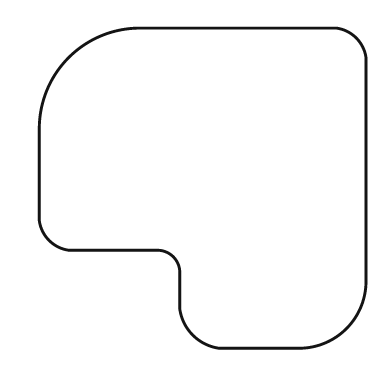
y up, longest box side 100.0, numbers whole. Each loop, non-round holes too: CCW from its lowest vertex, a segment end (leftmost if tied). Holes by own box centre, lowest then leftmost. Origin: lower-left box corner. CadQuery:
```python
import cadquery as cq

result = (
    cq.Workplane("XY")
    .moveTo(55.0, 0.0)
    .lineTo(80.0, 0.0)
    .threePointArc((94.0, 6.0), (100.0, 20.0))
    .lineTo(100.0, 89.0)
    .threePointArc((97.0, 95.0), (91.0, 98.0))
    .lineTo(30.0, 98.0)
    .threePointArc((9.0, 89.0), (0.0, 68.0))
    .lineTo(0.0, 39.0)
    .threePointArc((3.0, 33.0), (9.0, 30.0))
    .lineTo(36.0, 30.0)
    .threePointArc((41.0, 28.0), (43.0, 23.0))
    .lineTo(43.0, 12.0)
    .threePointArc((47.0, 4.0), (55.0, 0.0))
    .close()
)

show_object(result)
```